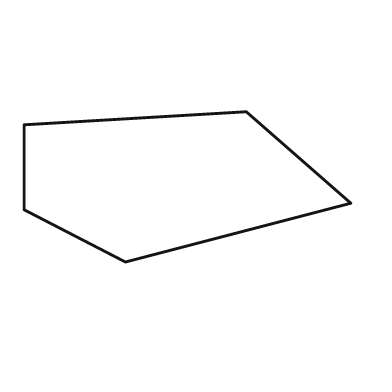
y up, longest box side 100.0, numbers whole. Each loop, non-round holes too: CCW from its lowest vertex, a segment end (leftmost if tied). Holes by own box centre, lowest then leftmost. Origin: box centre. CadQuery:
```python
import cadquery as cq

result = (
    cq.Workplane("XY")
    .moveTo(-19.0, -23.0)
    .lineTo(50.0, -5.0)
    .lineTo(18.0, 23.0)
    .lineTo(-50.0, 19.0)
    .lineTo(-50.0, -7.0)
    .close()
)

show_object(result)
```